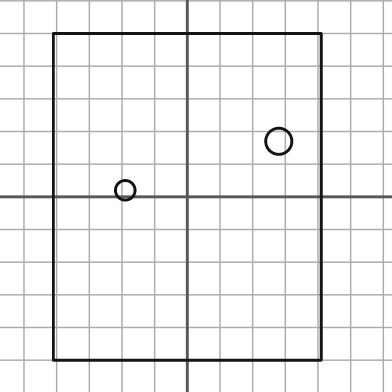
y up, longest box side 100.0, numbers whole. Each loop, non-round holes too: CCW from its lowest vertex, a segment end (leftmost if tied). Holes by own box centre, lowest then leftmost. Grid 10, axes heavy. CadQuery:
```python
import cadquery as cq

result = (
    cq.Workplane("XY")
    .moveTo(-41.0, -50.0)
    .lineTo(41.0, -50.0)
    .lineTo(41.0, 50.0)
    .lineTo(-41.0, 50.0)
    .close()
    .moveTo(-19.0, 2.0)
    .circle(3.0)
    .moveTo(28.0, 17.0)
    .circle(4.0)
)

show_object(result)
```